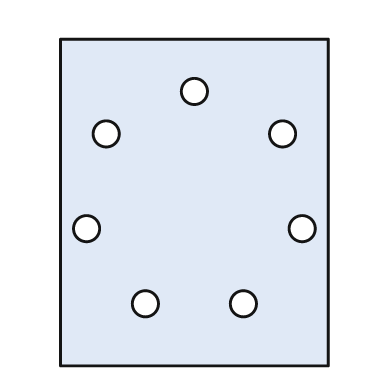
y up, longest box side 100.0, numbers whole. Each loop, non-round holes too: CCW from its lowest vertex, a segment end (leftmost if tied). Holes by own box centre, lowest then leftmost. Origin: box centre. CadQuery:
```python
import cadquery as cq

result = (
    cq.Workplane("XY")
    .moveTo(-41.0, -50.0)
    .lineTo(41.0, -50.0)
    .lineTo(41.0, 50.0)
    .lineTo(-41.0, 50.0)
    .close()
    .moveTo(-15.0, -31.0)
    .circle(4.0)
    .moveTo(15.0, -31.0)
    .circle(4.0)
    .moveTo(-33.0, -8.0)
    .circle(4.0)
    .moveTo(33.0, -8.0)
    .circle(4.0)
    .moveTo(-27.0, 21.0)
    .circle(4.0)
    .moveTo(27.0, 21.0)
    .circle(4.0)
    .moveTo(0.0, 34.0)
    .circle(4.0)
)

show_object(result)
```